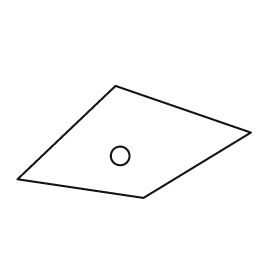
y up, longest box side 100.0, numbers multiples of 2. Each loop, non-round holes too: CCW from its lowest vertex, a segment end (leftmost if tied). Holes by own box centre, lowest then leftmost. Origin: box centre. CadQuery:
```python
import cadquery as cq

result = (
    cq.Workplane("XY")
    .moveTo(4.0, -24.0)
    .lineTo(50.0, 4.0)
    .lineTo(-8.0, 24.0)
    .lineTo(-50.0, -16.0)
    .close()
    .moveTo(-6.0, -6.0)
    .circle(4.0)
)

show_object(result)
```